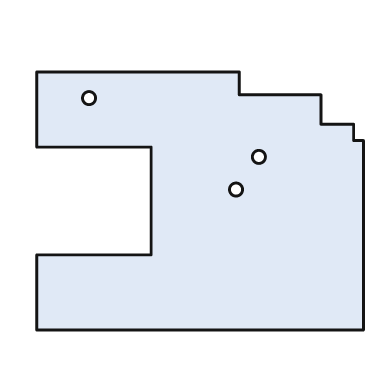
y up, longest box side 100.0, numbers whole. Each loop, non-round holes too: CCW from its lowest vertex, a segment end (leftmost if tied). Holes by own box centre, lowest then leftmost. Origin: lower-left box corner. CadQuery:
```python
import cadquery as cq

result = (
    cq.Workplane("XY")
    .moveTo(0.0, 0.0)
    .lineTo(100.0, 0.0)
    .lineTo(100.0, 58.0)
    .lineTo(97.0, 58.0)
    .lineTo(97.0, 63.0)
    .lineTo(87.0, 63.0)
    .lineTo(87.0, 72.0)
    .lineTo(62.0, 72.0)
    .lineTo(62.0, 79.0)
    .lineTo(0.0, 79.0)
    .lineTo(0.0, 56.0)
    .lineTo(35.0, 56.0)
    .lineTo(35.0, 23.0)
    .lineTo(0.0, 23.0)
    .close()
    .moveTo(61.0, 43.0)
    .circle(2.0)
    .moveTo(68.0, 53.0)
    .circle(2.0)
    .moveTo(16.0, 71.0)
    .circle(2.0)
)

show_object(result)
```